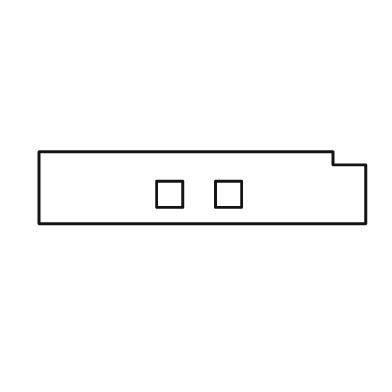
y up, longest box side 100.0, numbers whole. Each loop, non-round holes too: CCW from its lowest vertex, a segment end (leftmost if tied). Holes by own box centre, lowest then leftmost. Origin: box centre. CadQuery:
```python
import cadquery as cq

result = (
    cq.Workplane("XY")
    .moveTo(-50.0, -11.0)
    .lineTo(50.0, -11.0)
    .lineTo(50.0, 7.0)
    .lineTo(40.0, 7.0)
    .lineTo(40.0, 11.0)
    .lineTo(-50.0, 11.0)
    .close()
    .moveTo(-14.0, -6.0)
    .lineTo(-6.0, -6.0)
    .lineTo(-6.0, 2.0)
    .lineTo(-14.0, 2.0)
    .close()
    .moveTo(4.0, -6.0)
    .lineTo(12.0, -6.0)
    .lineTo(12.0, 2.0)
    .lineTo(4.0, 2.0)
    .close()
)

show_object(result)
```